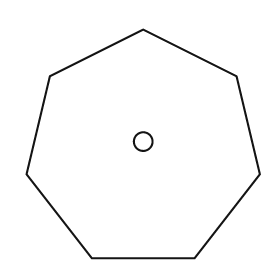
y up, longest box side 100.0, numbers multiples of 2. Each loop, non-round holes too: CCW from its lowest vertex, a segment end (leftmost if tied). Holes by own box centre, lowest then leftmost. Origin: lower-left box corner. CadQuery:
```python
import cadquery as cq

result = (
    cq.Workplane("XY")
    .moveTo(28.0, 0.0)
    .lineTo(72.0, 0.0)
    .lineTo(100.0, 36.0)
    .lineTo(90.0, 78.0)
    .lineTo(50.0, 98.0)
    .lineTo(10.0, 78.0)
    .lineTo(0.0, 36.0)
    .close()
    .moveTo(50.0, 50.0)
    .circle(4.0)
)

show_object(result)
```